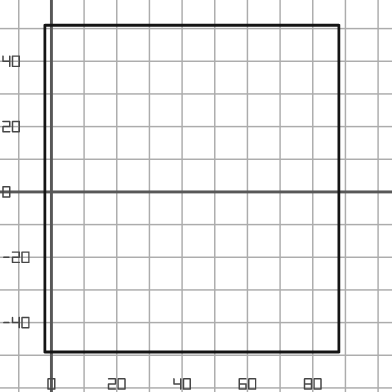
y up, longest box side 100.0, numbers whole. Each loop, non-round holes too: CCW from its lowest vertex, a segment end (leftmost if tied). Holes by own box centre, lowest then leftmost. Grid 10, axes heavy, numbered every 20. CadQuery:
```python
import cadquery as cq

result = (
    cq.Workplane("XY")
    .moveTo(-2.0, -49.0)
    .lineTo(88.0, -49.0)
    .lineTo(88.0, 51.0)
    .lineTo(-2.0, 51.0)
    .close()
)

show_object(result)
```